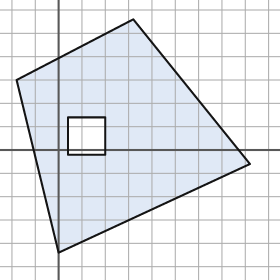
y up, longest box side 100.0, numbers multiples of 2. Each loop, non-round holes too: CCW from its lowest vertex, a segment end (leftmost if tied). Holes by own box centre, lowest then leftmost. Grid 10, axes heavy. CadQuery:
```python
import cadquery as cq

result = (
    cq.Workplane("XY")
    .moveTo(0.0, -44.0)
    .lineTo(82.0, -6.0)
    .lineTo(32.0, 56.0)
    .lineTo(-18.0, 30.0)
    .close()
    .moveTo(4.0, -2.0)
    .lineTo(20.0, -2.0)
    .lineTo(20.0, 14.0)
    .lineTo(4.0, 14.0)
    .close()
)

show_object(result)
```